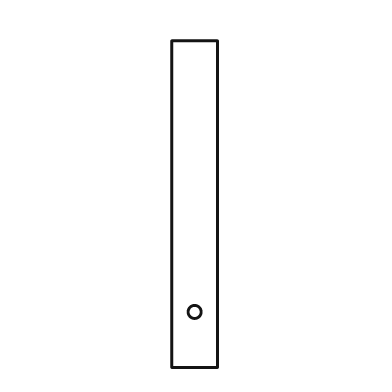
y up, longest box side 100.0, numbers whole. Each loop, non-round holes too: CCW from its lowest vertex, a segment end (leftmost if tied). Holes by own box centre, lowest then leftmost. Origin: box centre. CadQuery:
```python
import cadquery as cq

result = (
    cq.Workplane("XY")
    .moveTo(-7.0, -50.0)
    .lineTo(7.0, -50.0)
    .lineTo(7.0, 50.0)
    .lineTo(-7.0, 50.0)
    .close()
    .moveTo(0.0, -33.0)
    .circle(2.0)
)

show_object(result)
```